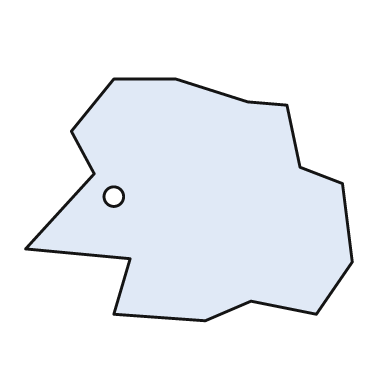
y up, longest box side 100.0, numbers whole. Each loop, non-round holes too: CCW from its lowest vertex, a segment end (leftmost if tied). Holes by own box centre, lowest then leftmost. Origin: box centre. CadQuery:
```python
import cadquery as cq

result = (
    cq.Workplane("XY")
    .moveTo(5.0, -37.0)
    .lineTo(19.0, -31.0)
    .lineTo(39.0, -35.0)
    .lineTo(50.0, -19.0)
    .lineTo(47.0, 5.0)
    .lineTo(34.0, 10.0)
    .lineTo(30.0, 29.0)
    .lineTo(18.0, 30.0)
    .lineTo(-4.0, 37.0)
    .lineTo(-23.0, 37.0)
    .lineTo(-36.0, 21.0)
    .lineTo(-29.0, 8.0)
    .lineTo(-50.0, -15.0)
    .lineTo(-18.0, -18.0)
    .lineTo(-23.0, -35.0)
    .close()
    .moveTo(-23.0, 1.0)
    .circle(3.0)
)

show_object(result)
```